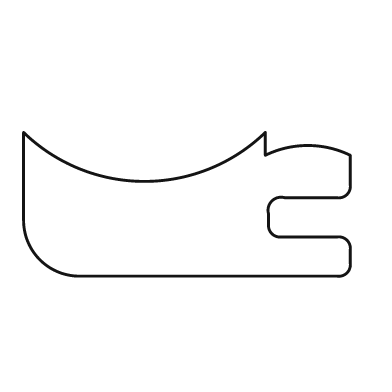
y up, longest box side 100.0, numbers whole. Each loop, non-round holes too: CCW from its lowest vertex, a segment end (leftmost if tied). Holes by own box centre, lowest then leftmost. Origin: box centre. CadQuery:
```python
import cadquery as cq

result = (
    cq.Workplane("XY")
    .moveTo(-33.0, -22.0)
    .lineTo(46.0, -22.0)
    .threePointArc((49.0, -21.0), (50.0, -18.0))
    .lineTo(50.0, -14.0)
    .threePointArc((49.0, -11.0), (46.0, -10.0))
    .lineTo(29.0, -10.0)
    .threePointArc((26.0, -9.0), (25.0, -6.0))
    .lineTo(25.0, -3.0)
    .threePointArc((26.0, 1.0), (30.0, 2.0))
    .lineTo(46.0, 2.0)
    .threePointArc((49.0, 3.0), (50.0, 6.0))
    .lineTo(50.0, 15.0)
    .threePointArc((37.0, 18.0), (24.0, 15.0))
    .lineTo(24.0, 22.0)
    .threePointArc((-13.0, 7.0), (-50.0, 22.0))
    .lineTo(-50.0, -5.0)
    .threePointArc((-45.0, -17.0), (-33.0, -22.0))
    .close()
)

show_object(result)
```